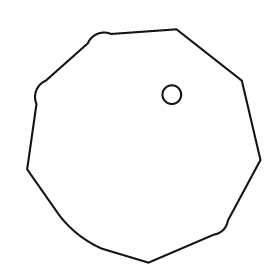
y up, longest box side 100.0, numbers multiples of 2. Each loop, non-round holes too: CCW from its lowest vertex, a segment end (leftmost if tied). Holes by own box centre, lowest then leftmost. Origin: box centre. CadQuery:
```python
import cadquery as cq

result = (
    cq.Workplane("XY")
    .moveTo(2.0, -50.0)
    .lineTo(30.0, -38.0)
    .threePointArc((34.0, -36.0), (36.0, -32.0))
    .lineTo(50.0, -6.0)
    .lineTo(42.0, 28.0)
    .lineTo(14.0, 50.0)
    .lineTo(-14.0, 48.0)
    .threePointArc((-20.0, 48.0), (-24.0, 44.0))
    .lineTo(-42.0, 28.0)
    .threePointArc((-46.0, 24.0), (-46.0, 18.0))
    .lineTo(-50.0, -10.0)
    .lineTo(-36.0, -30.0)
    .threePointArc((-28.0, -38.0), (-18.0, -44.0))
    .close()
    .moveTo(12.0, 22.0)
    .circle(4.0)
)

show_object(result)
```